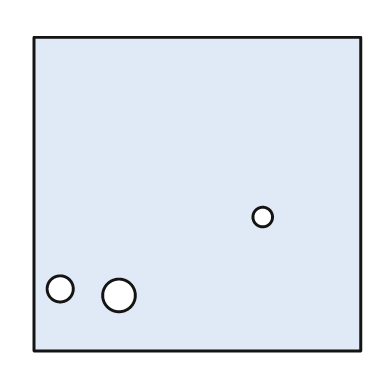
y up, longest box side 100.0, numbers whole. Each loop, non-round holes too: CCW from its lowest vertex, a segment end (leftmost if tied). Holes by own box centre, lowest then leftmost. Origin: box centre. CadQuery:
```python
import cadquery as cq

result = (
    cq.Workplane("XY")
    .moveTo(-50.0, -48.0)
    .lineTo(50.0, -48.0)
    .lineTo(50.0, 48.0)
    .lineTo(-50.0, 48.0)
    .close()
    .moveTo(-24.0, -31.0)
    .circle(5.0)
    .moveTo(-42.0, -29.0)
    .circle(4.0)
    .moveTo(20.0, -7.0)
    .circle(3.0)
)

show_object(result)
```